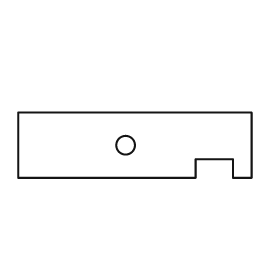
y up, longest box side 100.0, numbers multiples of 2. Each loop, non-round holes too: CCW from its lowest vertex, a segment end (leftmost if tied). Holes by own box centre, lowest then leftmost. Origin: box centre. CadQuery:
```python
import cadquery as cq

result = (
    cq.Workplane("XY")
    .moveTo(-50.0, -14.0)
    .lineTo(26.0, -14.0)
    .lineTo(26.0, -6.0)
    .lineTo(42.0, -6.0)
    .lineTo(42.0, -14.0)
    .lineTo(50.0, -14.0)
    .lineTo(50.0, 14.0)
    .lineTo(-50.0, 14.0)
    .close()
    .moveTo(-4.0, 0.0)
    .circle(4.0)
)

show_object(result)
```